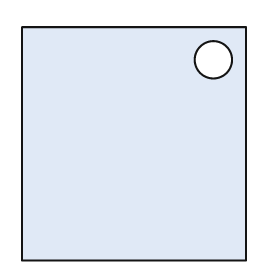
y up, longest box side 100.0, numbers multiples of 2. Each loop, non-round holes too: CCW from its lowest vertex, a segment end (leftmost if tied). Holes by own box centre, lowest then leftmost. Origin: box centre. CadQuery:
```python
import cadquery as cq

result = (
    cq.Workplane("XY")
    .moveTo(-48.0, -50.0)
    .lineTo(48.0, -50.0)
    .lineTo(48.0, 50.0)
    .lineTo(-48.0, 50.0)
    .close()
    .moveTo(34.0, 36.0)
    .circle(8.0)
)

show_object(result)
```